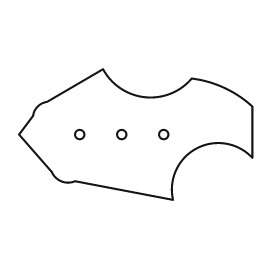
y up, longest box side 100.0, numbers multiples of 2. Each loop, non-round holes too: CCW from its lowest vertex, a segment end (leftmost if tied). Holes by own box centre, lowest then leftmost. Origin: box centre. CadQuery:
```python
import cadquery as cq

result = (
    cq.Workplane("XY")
    .moveTo(16.0, -28.0)
    .threePointArc((26.0, -6.0), (50.0, -10.0))
    .lineTo(50.0, 12.0)
    .threePointArc((38.0, 20.0), (24.0, 24.0))
    .threePointArc((4.0, 16.0), (-14.0, 28.0))
    .lineTo(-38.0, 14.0)
    .threePointArc((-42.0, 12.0), (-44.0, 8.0))
    .lineTo(-50.0, 0.0)
    .lineTo(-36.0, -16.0)
    .threePointArc((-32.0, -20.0), (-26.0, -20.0))
    .close()
    .moveTo(-24.0, 0.0)
    .circle(2.0)
    .moveTo(-6.0, 0.0)
    .circle(2.0)
    .moveTo(12.0, 0.0)
    .circle(2.0)
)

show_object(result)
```